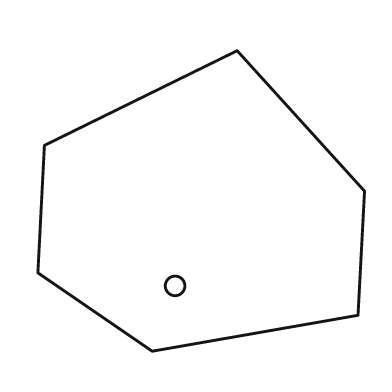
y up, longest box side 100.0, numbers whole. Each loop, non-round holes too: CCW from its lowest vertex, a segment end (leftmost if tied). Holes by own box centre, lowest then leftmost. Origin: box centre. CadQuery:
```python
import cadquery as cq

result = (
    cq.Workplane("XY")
    .moveTo(-15.0, -46.0)
    .lineTo(48.0, -35.0)
    .lineTo(50.0, 3.0)
    .lineTo(11.0, 46.0)
    .lineTo(-48.0, 17.0)
    .lineTo(-50.0, -22.0)
    .close()
    .moveTo(-8.0, -26.0)
    .circle(3.0)
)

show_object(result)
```